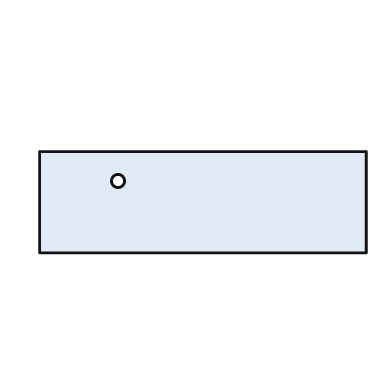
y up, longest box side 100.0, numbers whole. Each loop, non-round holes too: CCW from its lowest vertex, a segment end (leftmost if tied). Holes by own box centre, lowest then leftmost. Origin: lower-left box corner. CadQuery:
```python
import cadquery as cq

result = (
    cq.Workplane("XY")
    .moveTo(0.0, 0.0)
    .lineTo(100.0, 0.0)
    .lineTo(100.0, 31.0)
    .lineTo(0.0, 31.0)
    .close()
    .moveTo(24.0, 22.0)
    .circle(2.0)
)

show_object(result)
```